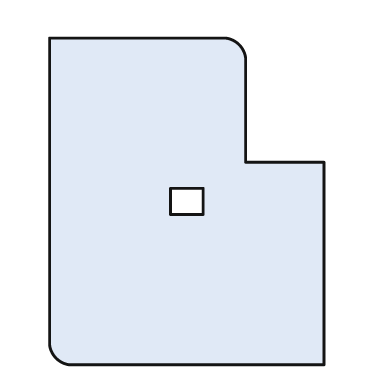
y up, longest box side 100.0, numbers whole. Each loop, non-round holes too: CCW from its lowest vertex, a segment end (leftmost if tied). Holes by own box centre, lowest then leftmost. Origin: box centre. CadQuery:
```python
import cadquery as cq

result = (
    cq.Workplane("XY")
    .moveTo(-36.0, -50.0)
    .lineTo(42.0, -50.0)
    .lineTo(42.0, 12.0)
    .lineTo(18.0, 12.0)
    .lineTo(18.0, 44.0)
    .threePointArc((16.0, 48.0), (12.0, 50.0))
    .lineTo(-42.0, 50.0)
    .lineTo(-42.0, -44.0)
    .threePointArc((-40.0, -48.0), (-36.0, -50.0))
    .close()
    .moveTo(-5.0, -4.0)
    .lineTo(5.0, -4.0)
    .lineTo(5.0, 4.0)
    .lineTo(-5.0, 4.0)
    .close()
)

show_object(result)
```